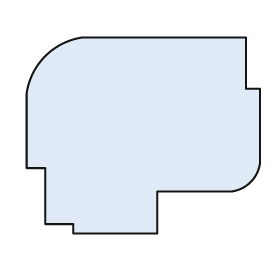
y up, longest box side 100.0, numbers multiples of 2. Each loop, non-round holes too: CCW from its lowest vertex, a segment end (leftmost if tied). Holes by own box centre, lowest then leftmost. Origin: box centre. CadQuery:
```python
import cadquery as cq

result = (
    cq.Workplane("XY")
    .moveTo(-30.0, -42.0)
    .lineTo(6.0, -42.0)
    .lineTo(6.0, -24.0)
    .lineTo(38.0, -24.0)
    .threePointArc((46.0, -20.0), (50.0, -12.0))
    .lineTo(50.0, 20.0)
    .lineTo(44.0, 20.0)
    .lineTo(44.0, 42.0)
    .lineTo(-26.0, 42.0)
    .threePointArc((-42.0, 34.0), (-50.0, 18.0))
    .lineTo(-50.0, -14.0)
    .lineTo(-42.0, -14.0)
    .lineTo(-42.0, -38.0)
    .lineTo(-30.0, -38.0)
    .close()
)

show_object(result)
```